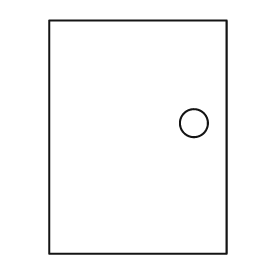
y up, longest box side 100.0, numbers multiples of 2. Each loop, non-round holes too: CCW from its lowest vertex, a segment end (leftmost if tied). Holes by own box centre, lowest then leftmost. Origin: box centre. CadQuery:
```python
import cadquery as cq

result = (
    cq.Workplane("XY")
    .moveTo(-38.0, -50.0)
    .lineTo(38.0, -50.0)
    .lineTo(38.0, 50.0)
    .lineTo(-38.0, 50.0)
    .close()
    .moveTo(24.0, 6.0)
    .circle(6.0)
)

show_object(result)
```